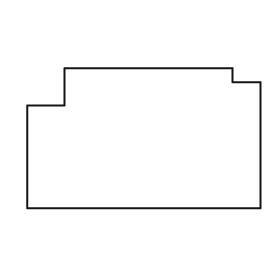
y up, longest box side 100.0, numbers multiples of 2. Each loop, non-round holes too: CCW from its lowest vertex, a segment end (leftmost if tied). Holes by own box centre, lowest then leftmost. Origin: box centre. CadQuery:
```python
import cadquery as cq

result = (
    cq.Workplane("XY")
    .moveTo(-50.0, -30.0)
    .lineTo(50.0, -30.0)
    .lineTo(50.0, 24.0)
    .lineTo(38.0, 24.0)
    .lineTo(38.0, 30.0)
    .lineTo(-34.0, 30.0)
    .lineTo(-34.0, 14.0)
    .lineTo(-50.0, 14.0)
    .close()
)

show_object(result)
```